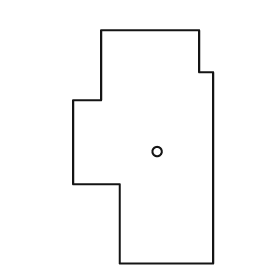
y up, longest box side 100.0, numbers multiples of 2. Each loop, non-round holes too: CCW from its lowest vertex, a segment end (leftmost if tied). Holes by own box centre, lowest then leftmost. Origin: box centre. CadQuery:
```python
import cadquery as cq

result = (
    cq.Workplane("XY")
    .moveTo(-10.0, -50.0)
    .lineTo(30.0, -50.0)
    .lineTo(30.0, 32.0)
    .lineTo(24.0, 32.0)
    .lineTo(24.0, 50.0)
    .lineTo(-18.0, 50.0)
    .lineTo(-18.0, 20.0)
    .lineTo(-30.0, 20.0)
    .lineTo(-30.0, -16.0)
    .lineTo(-10.0, -16.0)
    .close()
    .moveTo(6.0, -2.0)
    .circle(2.0)
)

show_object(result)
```